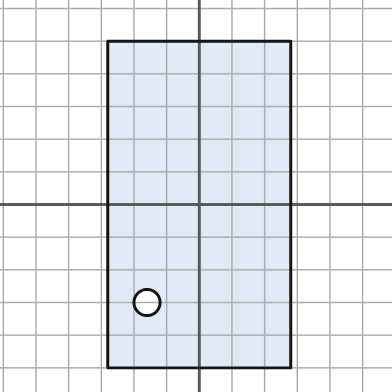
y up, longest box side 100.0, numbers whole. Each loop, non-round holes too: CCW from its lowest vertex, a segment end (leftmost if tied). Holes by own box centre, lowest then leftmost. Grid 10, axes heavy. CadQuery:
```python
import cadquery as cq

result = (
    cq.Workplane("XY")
    .moveTo(-28.0, -50.0)
    .lineTo(28.0, -50.0)
    .lineTo(28.0, 50.0)
    .lineTo(-28.0, 50.0)
    .close()
    .moveTo(-16.0, -30.0)
    .circle(4.0)
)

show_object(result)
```